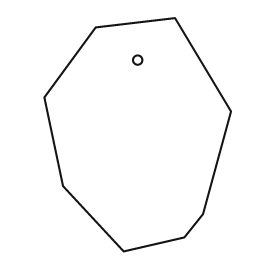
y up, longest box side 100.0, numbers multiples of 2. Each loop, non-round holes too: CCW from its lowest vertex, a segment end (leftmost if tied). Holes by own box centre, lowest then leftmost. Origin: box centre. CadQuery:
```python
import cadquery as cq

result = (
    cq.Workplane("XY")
    .moveTo(-6.0, -50.0)
    .lineTo(20.0, -44.0)
    .lineTo(28.0, -34.0)
    .lineTo(40.0, 10.0)
    .lineTo(16.0, 50.0)
    .lineTo(-18.0, 46.0)
    .lineTo(-40.0, 16.0)
    .lineTo(-32.0, -22.0)
    .close()
    .moveTo(0.0, 32.0)
    .circle(2.0)
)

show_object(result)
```